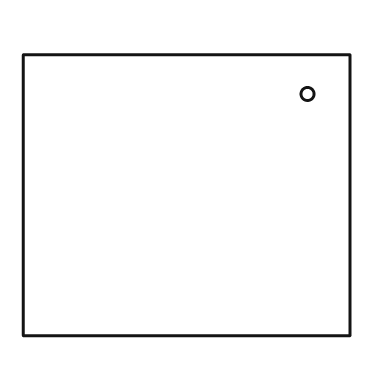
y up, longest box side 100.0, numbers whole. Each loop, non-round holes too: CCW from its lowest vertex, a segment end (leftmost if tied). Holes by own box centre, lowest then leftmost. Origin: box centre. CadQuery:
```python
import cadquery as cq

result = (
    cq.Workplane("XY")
    .moveTo(-50.0, -43.0)
    .lineTo(50.0, -43.0)
    .lineTo(50.0, 43.0)
    .lineTo(-50.0, 43.0)
    .close()
    .moveTo(37.0, 31.0)
    .circle(2.0)
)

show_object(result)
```